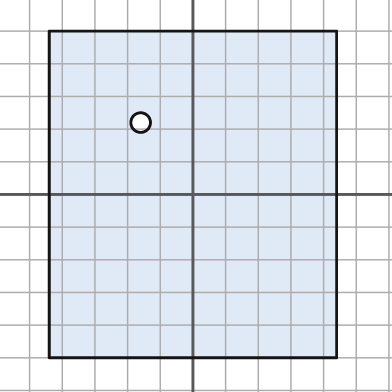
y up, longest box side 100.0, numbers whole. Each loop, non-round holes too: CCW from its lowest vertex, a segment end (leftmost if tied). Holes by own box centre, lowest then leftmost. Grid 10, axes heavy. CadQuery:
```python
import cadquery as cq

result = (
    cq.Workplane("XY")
    .moveTo(-44.0, -50.0)
    .lineTo(44.0, -50.0)
    .lineTo(44.0, 50.0)
    .lineTo(-44.0, 50.0)
    .close()
    .moveTo(-16.0, 22.0)
    .circle(3.0)
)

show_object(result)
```